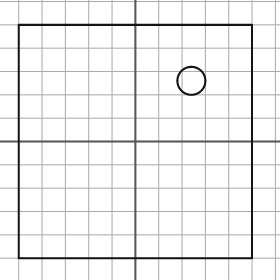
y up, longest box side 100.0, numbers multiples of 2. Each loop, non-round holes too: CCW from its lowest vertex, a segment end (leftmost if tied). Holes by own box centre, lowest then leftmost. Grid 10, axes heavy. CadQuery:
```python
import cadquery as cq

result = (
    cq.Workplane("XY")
    .moveTo(-50.0, -50.0)
    .lineTo(50.0, -50.0)
    .lineTo(50.0, 50.0)
    .lineTo(-50.0, 50.0)
    .close()
    .moveTo(24.0, 26.0)
    .circle(6.0)
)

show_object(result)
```